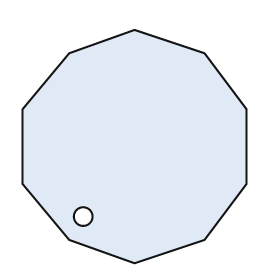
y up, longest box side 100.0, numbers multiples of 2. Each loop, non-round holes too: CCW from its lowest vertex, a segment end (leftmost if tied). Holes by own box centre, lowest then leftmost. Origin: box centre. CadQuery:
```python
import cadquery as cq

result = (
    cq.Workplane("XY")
    .moveTo(0.0, -50.0)
    .lineTo(30.0, -40.0)
    .lineTo(48.0, -16.0)
    .lineTo(48.0, 16.0)
    .lineTo(30.0, 40.0)
    .lineTo(0.0, 50.0)
    .lineTo(-28.0, 40.0)
    .lineTo(-48.0, 16.0)
    .lineTo(-48.0, -16.0)
    .lineTo(-28.0, -40.0)
    .close()
    .moveTo(-22.0, -30.0)
    .circle(4.0)
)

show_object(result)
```